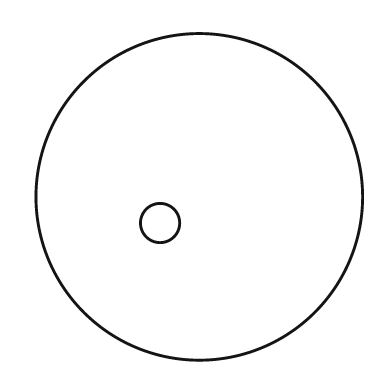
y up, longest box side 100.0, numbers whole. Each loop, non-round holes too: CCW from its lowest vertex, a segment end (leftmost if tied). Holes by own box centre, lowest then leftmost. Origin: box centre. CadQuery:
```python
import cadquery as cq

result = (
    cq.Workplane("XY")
    .moveTo(0.0, 0.0)
    .circle(50.0)
    .moveTo(-12.0, -8.0)
    .circle(6.0)
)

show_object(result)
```